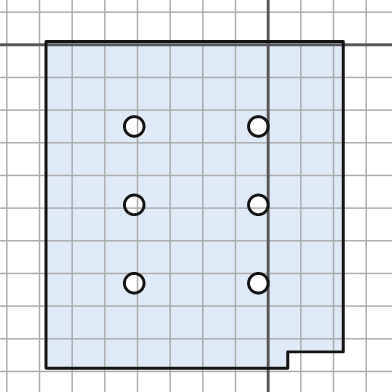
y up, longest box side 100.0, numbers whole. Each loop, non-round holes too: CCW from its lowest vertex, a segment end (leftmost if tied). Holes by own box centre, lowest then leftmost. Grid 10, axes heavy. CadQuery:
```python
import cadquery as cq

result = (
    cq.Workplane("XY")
    .moveTo(-68.0, -99.0)
    .lineTo(6.0, -99.0)
    .lineTo(6.0, -94.0)
    .lineTo(23.0, -94.0)
    .lineTo(23.0, 1.0)
    .lineTo(-68.0, 1.0)
    .close()
    .moveTo(-41.0, -73.0)
    .circle(3.0)
    .moveTo(-3.0, -73.0)
    .circle(3.0)
    .moveTo(-41.0, -49.0)
    .circle(3.0)
    .moveTo(-3.0, -49.0)
    .circle(3.0)
    .moveTo(-41.0, -25.0)
    .circle(3.0)
    .moveTo(-3.0, -25.0)
    .circle(3.0)
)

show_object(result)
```